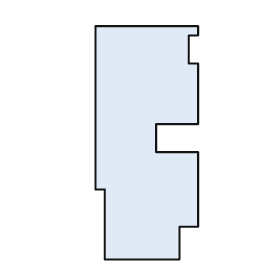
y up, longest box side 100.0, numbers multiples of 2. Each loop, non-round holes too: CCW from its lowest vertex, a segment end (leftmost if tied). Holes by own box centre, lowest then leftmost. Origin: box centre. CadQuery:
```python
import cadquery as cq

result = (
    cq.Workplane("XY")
    .moveTo(-18.0, -50.0)
    .lineTo(14.0, -50.0)
    .lineTo(14.0, -36.0)
    .lineTo(22.0, -36.0)
    .lineTo(22.0, -4.0)
    .lineTo(4.0, -4.0)
    .lineTo(4.0, 8.0)
    .lineTo(22.0, 8.0)
    .lineTo(22.0, 34.0)
    .lineTo(18.0, 34.0)
    .lineTo(18.0, 46.0)
    .lineTo(22.0, 46.0)
    .lineTo(22.0, 50.0)
    .lineTo(-22.0, 50.0)
    .lineTo(-22.0, -20.0)
    .lineTo(-18.0, -20.0)
    .close()
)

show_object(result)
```